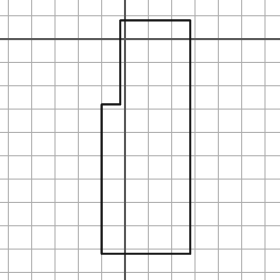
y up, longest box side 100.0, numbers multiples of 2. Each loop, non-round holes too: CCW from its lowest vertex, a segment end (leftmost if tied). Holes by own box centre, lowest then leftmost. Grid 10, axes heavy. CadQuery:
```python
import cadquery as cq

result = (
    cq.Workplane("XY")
    .moveTo(-10.0, -92.0)
    .lineTo(28.0, -92.0)
    .lineTo(28.0, 8.0)
    .lineTo(-2.0, 8.0)
    .lineTo(-2.0, -28.0)
    .lineTo(-10.0, -28.0)
    .close()
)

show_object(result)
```